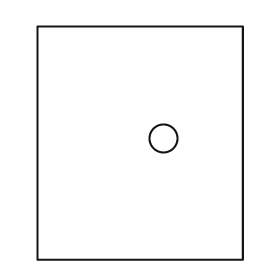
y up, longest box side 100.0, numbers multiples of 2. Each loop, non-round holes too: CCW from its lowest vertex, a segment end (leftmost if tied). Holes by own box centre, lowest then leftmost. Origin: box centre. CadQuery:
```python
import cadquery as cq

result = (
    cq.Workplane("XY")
    .moveTo(-44.0, -50.0)
    .lineTo(44.0, -50.0)
    .lineTo(44.0, 50.0)
    .lineTo(-44.0, 50.0)
    .close()
    .moveTo(10.0, 2.0)
    .circle(6.0)
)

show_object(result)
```